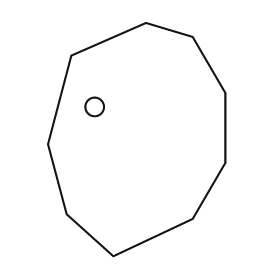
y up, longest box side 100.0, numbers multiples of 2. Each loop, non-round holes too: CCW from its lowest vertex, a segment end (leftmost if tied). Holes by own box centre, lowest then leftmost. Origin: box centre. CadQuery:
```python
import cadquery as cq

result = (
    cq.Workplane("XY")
    .moveTo(-10.0, -50.0)
    .lineTo(24.0, -34.0)
    .lineTo(38.0, -10.0)
    .lineTo(38.0, 20.0)
    .lineTo(24.0, 44.0)
    .lineTo(4.0, 50.0)
    .lineTo(-28.0, 36.0)
    .lineTo(-38.0, -2.0)
    .lineTo(-30.0, -32.0)
    .close()
    .moveTo(-18.0, 14.0)
    .circle(4.0)
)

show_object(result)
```